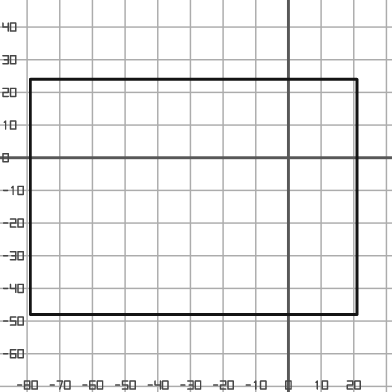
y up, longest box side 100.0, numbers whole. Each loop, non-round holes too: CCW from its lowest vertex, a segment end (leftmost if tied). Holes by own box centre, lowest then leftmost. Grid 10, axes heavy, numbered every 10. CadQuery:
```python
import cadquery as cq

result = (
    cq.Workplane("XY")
    .moveTo(-79.0, -48.0)
    .lineTo(21.0, -48.0)
    .lineTo(21.0, 24.0)
    .lineTo(-79.0, 24.0)
    .close()
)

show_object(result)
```